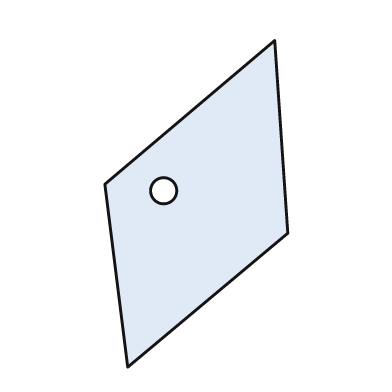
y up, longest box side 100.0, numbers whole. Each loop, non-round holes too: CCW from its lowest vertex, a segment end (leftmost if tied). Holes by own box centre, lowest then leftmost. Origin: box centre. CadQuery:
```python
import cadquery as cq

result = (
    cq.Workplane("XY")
    .moveTo(-21.0, -50.0)
    .lineTo(28.0, -9.0)
    .lineTo(24.0, 50.0)
    .lineTo(-28.0, 6.0)
    .close()
    .moveTo(-10.0, 4.0)
    .circle(4.0)
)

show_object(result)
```